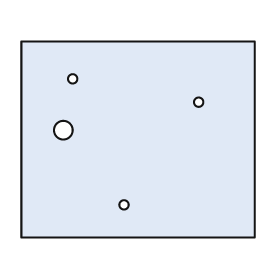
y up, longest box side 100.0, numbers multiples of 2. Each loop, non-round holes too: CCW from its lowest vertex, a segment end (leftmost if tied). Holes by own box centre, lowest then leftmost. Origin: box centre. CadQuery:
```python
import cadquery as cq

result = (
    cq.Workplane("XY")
    .moveTo(-50.0, -42.0)
    .lineTo(50.0, -42.0)
    .lineTo(50.0, 42.0)
    .lineTo(-50.0, 42.0)
    .close()
    .moveTo(-6.0, -28.0)
    .circle(2.0)
    .moveTo(-32.0, 4.0)
    .circle(4.0)
    .moveTo(26.0, 16.0)
    .circle(2.0)
    .moveTo(-28.0, 26.0)
    .circle(2.0)
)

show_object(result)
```